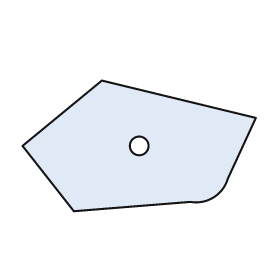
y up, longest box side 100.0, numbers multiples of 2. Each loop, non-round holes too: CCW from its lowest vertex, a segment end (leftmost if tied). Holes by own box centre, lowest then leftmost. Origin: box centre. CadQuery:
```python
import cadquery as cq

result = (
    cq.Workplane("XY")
    .moveTo(-28.0, -28.0)
    .lineTo(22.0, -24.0)
    .threePointArc((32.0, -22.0), (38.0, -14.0))
    .lineTo(50.0, 12.0)
    .lineTo(-16.0, 28.0)
    .lineTo(-50.0, 0.0)
    .close()
    .moveTo(0.0, 0.0)
    .circle(4.0)
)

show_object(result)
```